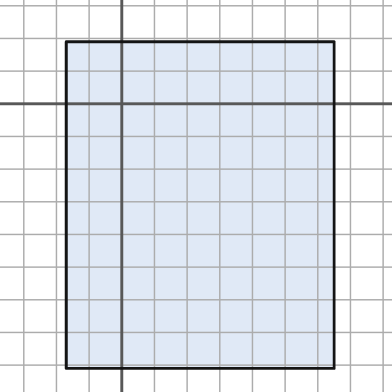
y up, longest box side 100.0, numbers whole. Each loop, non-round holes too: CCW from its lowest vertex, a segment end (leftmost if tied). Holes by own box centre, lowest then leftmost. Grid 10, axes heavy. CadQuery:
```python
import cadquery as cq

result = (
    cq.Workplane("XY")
    .moveTo(-17.0, -81.0)
    .lineTo(65.0, -81.0)
    .lineTo(65.0, 19.0)
    .lineTo(-17.0, 19.0)
    .close()
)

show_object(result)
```